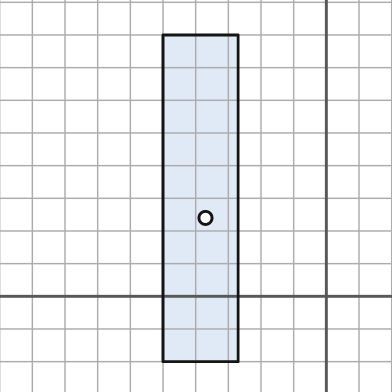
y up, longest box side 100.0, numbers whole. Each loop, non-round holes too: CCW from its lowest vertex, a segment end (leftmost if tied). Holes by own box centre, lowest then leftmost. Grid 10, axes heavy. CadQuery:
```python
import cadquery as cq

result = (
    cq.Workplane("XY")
    .moveTo(-50.0, -20.0)
    .lineTo(-27.0, -20.0)
    .lineTo(-27.0, 80.0)
    .lineTo(-50.0, 80.0)
    .close()
    .moveTo(-37.0, 24.0)
    .circle(2.0)
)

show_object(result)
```